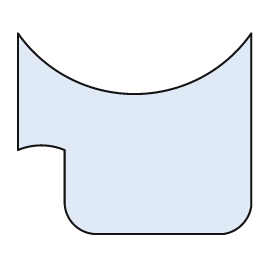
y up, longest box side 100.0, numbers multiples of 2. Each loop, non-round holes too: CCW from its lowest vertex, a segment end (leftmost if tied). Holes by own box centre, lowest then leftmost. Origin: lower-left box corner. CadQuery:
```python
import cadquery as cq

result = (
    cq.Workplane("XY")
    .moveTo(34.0, 0.0)
    .lineTo(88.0, 0.0)
    .threePointArc((96.0, 4.0), (100.0, 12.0))
    .lineTo(100.0, 86.0)
    .threePointArc((50.0, 60.0), (0.0, 86.0))
    .lineTo(0.0, 36.0)
    .threePointArc((10.0, 38.0), (20.0, 36.0))
    .lineTo(20.0, 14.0)
    .threePointArc((24.0, 4.0), (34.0, 0.0))
    .close()
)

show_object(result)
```